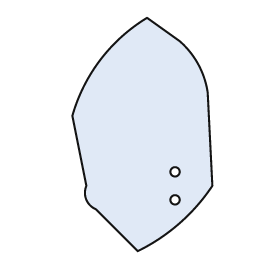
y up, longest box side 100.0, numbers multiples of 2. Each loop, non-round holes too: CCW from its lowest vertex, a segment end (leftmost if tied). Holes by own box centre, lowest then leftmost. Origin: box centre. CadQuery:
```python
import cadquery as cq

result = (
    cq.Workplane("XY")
    .moveTo(-2.0, -50.0)
    .threePointArc((16.0, -38.0), (30.0, -22.0))
    .lineTo(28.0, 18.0)
    .threePointArc((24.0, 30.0), (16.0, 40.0))
    .lineTo(2.0, 50.0)
    .threePointArc((-18.0, 32.0), (-30.0, 8.0))
    .lineTo(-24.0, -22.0)
    .threePointArc((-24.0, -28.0), (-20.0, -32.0))
    .close()
    .moveTo(14.0, -28.0)
    .circle(2.0)
    .moveTo(14.0, -16.0)
    .circle(2.0)
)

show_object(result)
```